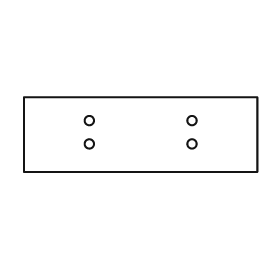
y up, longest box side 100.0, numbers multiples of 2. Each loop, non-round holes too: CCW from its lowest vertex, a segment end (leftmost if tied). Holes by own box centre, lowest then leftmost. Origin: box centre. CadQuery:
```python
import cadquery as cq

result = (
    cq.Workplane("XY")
    .moveTo(-50.0, -16.0)
    .lineTo(50.0, -16.0)
    .lineTo(50.0, 16.0)
    .lineTo(-50.0, 16.0)
    .close()
    .moveTo(-22.0, -4.0)
    .circle(2.0)
    .moveTo(22.0, -4.0)
    .circle(2.0)
    .moveTo(-22.0, 6.0)
    .circle(2.0)
    .moveTo(22.0, 6.0)
    .circle(2.0)
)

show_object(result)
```